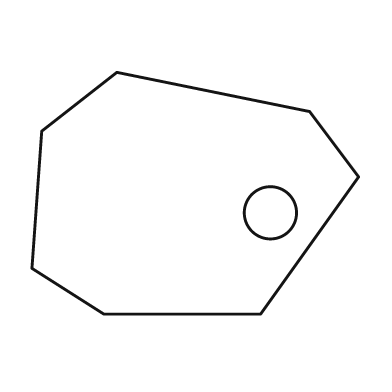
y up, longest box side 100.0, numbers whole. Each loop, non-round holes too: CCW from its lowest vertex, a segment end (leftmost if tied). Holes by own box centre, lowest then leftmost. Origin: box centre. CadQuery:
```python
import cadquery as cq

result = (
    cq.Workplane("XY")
    .moveTo(-28.0, -37.0)
    .lineTo(20.0, -37.0)
    .lineTo(50.0, 5.0)
    .lineTo(35.0, 25.0)
    .lineTo(-24.0, 37.0)
    .lineTo(-47.0, 19.0)
    .lineTo(-50.0, -23.0)
    .close()
    .moveTo(23.0, -6.0)
    .circle(8.0)
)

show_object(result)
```